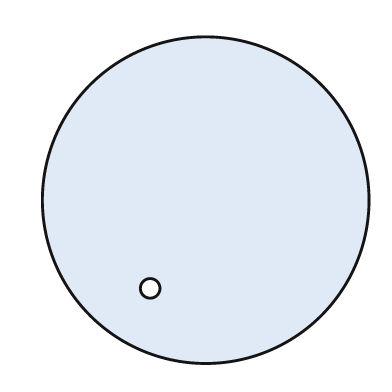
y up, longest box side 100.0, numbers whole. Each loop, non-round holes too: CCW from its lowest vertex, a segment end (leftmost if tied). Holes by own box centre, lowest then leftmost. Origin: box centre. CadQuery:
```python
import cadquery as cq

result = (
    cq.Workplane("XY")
    .moveTo(0.0, 0.0)
    .circle(50.0)
    .moveTo(-17.0, -27.0)
    .circle(3.0)
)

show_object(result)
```